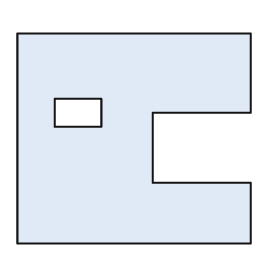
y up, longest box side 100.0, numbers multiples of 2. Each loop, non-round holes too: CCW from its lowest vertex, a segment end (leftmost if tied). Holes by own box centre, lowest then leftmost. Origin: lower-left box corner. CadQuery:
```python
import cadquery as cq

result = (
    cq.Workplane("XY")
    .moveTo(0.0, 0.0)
    .lineTo(100.0, 0.0)
    .lineTo(100.0, 26.0)
    .lineTo(58.0, 26.0)
    .lineTo(58.0, 56.0)
    .lineTo(100.0, 56.0)
    .lineTo(100.0, 90.0)
    .lineTo(0.0, 90.0)
    .close()
    .moveTo(16.0, 50.0)
    .lineTo(36.0, 50.0)
    .lineTo(36.0, 62.0)
    .lineTo(16.0, 62.0)
    .close()
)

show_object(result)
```